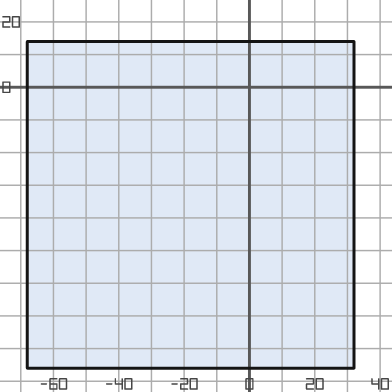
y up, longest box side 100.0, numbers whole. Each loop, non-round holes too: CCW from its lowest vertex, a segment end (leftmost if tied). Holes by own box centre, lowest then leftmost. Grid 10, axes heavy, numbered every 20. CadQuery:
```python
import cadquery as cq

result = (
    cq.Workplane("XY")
    .moveTo(-68.0, -86.0)
    .lineTo(32.0, -86.0)
    .lineTo(32.0, 14.0)
    .lineTo(-68.0, 14.0)
    .close()
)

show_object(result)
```